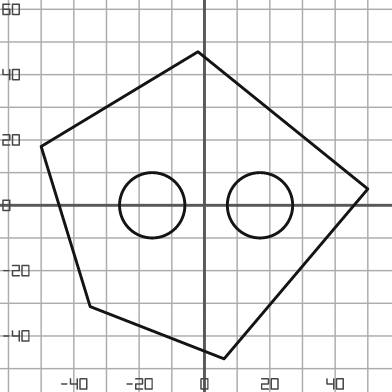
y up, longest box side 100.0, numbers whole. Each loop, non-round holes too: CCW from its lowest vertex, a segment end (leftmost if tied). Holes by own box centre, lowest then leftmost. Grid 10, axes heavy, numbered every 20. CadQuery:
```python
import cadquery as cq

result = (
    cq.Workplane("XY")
    .moveTo(6.0, -47.0)
    .lineTo(50.0, 5.0)
    .lineTo(-2.0, 47.0)
    .lineTo(-50.0, 18.0)
    .lineTo(-35.0, -31.0)
    .close()
    .moveTo(-16.0, 0.0)
    .circle(10.0)
    .moveTo(17.0, 0.0)
    .circle(10.0)
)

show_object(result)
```